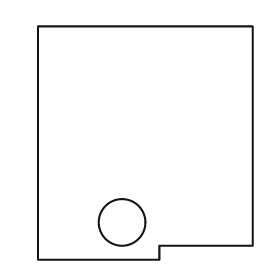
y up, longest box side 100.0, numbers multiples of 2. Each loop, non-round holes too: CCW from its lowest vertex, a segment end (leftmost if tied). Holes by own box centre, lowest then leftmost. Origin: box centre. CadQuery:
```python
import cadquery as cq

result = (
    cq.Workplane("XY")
    .moveTo(-46.0, -50.0)
    .lineTo(6.0, -50.0)
    .lineTo(6.0, -44.0)
    .lineTo(46.0, -44.0)
    .lineTo(46.0, 50.0)
    .lineTo(-46.0, 50.0)
    .close()
    .moveTo(-10.0, -34.0)
    .circle(10.0)
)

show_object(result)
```